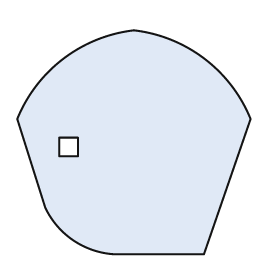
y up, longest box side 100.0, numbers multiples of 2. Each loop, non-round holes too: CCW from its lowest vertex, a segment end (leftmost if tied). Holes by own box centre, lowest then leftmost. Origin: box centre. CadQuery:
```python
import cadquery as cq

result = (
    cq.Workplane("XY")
    .moveTo(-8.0, -48.0)
    .lineTo(30.0, -48.0)
    .lineTo(50.0, 10.0)
    .threePointArc((30.0, 36.0), (0.0, 48.0))
    .threePointArc((-30.0, 36.0), (-50.0, 10.0))
    .lineTo(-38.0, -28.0)
    .threePointArc((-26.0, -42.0), (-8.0, -48.0))
    .close()
    .moveTo(-32.0, -6.0)
    .lineTo(-24.0, -6.0)
    .lineTo(-24.0, 2.0)
    .lineTo(-32.0, 2.0)
    .close()
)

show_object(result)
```